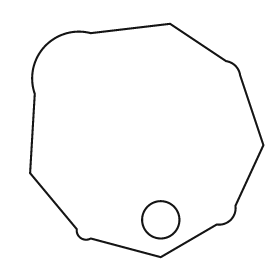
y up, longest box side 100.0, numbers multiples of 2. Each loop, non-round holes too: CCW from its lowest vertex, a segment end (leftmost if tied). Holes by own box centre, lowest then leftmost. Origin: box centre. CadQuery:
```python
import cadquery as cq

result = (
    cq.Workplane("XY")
    .moveTo(6.0, -50.0)
    .lineTo(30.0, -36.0)
    .threePointArc((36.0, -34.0), (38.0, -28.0))
    .lineTo(50.0, -2.0)
    .lineTo(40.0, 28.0)
    .threePointArc((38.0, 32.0), (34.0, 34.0))
    .lineTo(10.0, 50.0)
    .lineTo(-24.0, 46.0)
    .threePointArc((-44.0, 40.0), (-48.0, 20.0))
    .lineTo(-50.0, -14.0)
    .lineTo(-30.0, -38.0)
    .threePointArc((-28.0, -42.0), (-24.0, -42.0))
    .close()
    .moveTo(6.0, -34.0)
    .circle(8.0)
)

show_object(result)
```